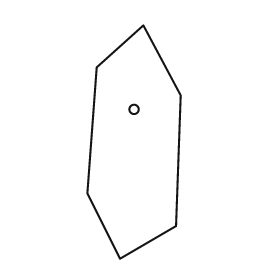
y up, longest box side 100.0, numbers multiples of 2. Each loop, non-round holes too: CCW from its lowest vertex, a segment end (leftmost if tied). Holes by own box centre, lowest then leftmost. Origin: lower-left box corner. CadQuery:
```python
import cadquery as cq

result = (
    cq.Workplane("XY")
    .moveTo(14.0, 0.0)
    .lineTo(38.0, 14.0)
    .lineTo(40.0, 70.0)
    .lineTo(24.0, 100.0)
    .lineTo(4.0, 82.0)
    .lineTo(0.0, 28.0)
    .close()
    .moveTo(20.0, 64.0)
    .circle(2.0)
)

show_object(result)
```